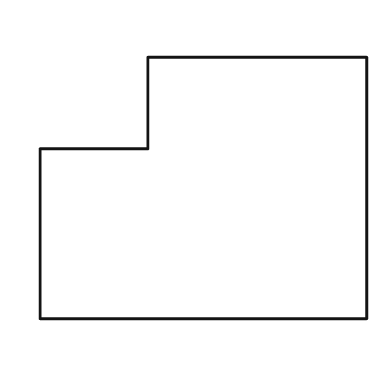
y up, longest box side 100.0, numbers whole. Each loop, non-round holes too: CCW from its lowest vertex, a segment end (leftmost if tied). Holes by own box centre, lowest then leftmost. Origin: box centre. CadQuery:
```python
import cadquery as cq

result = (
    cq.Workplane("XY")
    .moveTo(-50.0, -40.0)
    .lineTo(50.0, -40.0)
    .lineTo(50.0, 40.0)
    .lineTo(-17.0, 40.0)
    .lineTo(-17.0, 12.0)
    .lineTo(-50.0, 12.0)
    .close()
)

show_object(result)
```